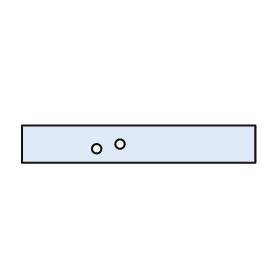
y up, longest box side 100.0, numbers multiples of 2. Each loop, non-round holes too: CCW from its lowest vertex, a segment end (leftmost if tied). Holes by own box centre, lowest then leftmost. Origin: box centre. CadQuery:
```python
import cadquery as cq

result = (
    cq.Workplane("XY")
    .moveTo(-50.0, -8.0)
    .lineTo(50.0, -8.0)
    .lineTo(50.0, 8.0)
    .lineTo(-50.0, 8.0)
    .close()
    .moveTo(-18.0, -2.0)
    .circle(2.0)
    .moveTo(-8.0, 0.0)
    .circle(2.0)
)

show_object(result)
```